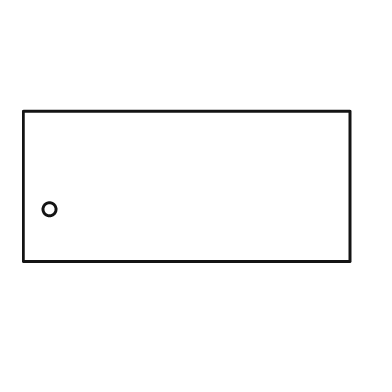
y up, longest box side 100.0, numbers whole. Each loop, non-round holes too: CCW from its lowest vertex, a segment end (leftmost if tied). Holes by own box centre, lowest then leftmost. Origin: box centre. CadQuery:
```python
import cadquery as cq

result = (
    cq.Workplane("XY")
    .moveTo(-50.0, -23.0)
    .lineTo(50.0, -23.0)
    .lineTo(50.0, 23.0)
    .lineTo(-50.0, 23.0)
    .close()
    .moveTo(-42.0, -7.0)
    .circle(2.0)
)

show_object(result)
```